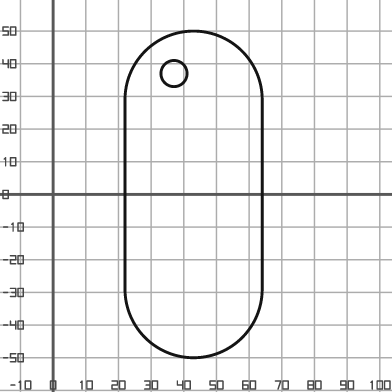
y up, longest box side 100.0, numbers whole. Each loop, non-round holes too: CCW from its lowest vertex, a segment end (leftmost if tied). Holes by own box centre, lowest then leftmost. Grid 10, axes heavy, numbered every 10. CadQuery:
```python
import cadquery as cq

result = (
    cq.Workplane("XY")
    .moveTo(22.0, -29.0)
    .threePointArc((43.0, -50.0), (64.0, -29.0))
    .lineTo(64.0, 29.0)
    .threePointArc((43.0, 50.0), (22.0, 29.0))
    .close()
    .moveTo(37.0, 37.0)
    .circle(4.0)
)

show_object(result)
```